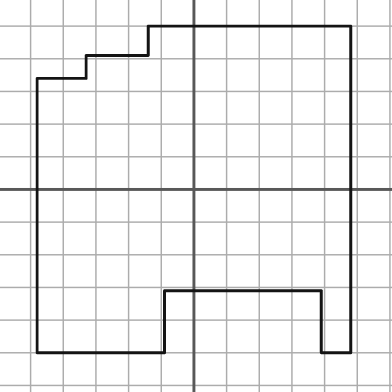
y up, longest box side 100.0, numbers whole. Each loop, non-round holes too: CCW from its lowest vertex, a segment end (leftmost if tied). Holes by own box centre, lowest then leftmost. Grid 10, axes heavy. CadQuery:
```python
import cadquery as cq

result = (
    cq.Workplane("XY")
    .moveTo(-48.0, -50.0)
    .lineTo(-9.0, -50.0)
    .lineTo(-9.0, -31.0)
    .lineTo(39.0, -31.0)
    .lineTo(39.0, -50.0)
    .lineTo(48.0, -50.0)
    .lineTo(48.0, 50.0)
    .lineTo(-14.0, 50.0)
    .lineTo(-14.0, 41.0)
    .lineTo(-33.0, 41.0)
    .lineTo(-33.0, 34.0)
    .lineTo(-48.0, 34.0)
    .close()
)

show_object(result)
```